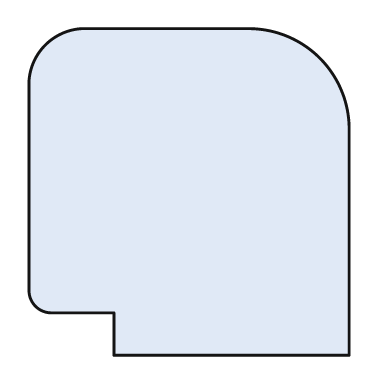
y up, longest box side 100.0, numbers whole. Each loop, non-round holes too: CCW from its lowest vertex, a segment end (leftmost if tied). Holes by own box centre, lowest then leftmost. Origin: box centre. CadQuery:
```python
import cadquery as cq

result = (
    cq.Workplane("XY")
    .moveTo(-23.0, -50.0)
    .lineTo(49.0, -50.0)
    .lineTo(49.0, 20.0)
    .threePointArc((40.0, 41.0), (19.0, 50.0))
    .lineTo(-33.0, 50.0)
    .threePointArc((-44.0, 45.0), (-49.0, 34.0))
    .lineTo(-49.0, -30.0)
    .threePointArc((-47.0, -35.0), (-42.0, -37.0))
    .lineTo(-23.0, -37.0)
    .close()
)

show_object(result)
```